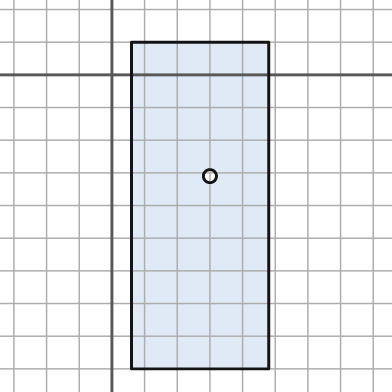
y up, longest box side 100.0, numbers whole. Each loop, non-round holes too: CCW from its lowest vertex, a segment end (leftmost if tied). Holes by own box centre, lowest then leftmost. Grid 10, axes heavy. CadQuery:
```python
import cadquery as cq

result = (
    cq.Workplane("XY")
    .moveTo(6.0, -90.0)
    .lineTo(48.0, -90.0)
    .lineTo(48.0, 10.0)
    .lineTo(6.0, 10.0)
    .close()
    .moveTo(30.0, -31.0)
    .circle(2.0)
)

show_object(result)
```